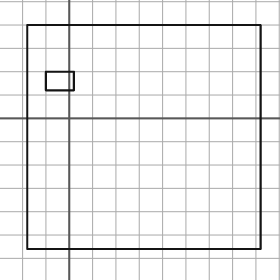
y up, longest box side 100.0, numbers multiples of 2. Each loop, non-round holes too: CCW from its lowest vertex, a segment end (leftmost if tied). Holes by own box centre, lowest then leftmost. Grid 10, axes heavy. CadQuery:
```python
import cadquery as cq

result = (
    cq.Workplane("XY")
    .moveTo(-18.0, -56.0)
    .lineTo(82.0, -56.0)
    .lineTo(82.0, 40.0)
    .lineTo(-18.0, 40.0)
    .close()
    .moveTo(-10.0, 12.0)
    .lineTo(2.0, 12.0)
    .lineTo(2.0, 20.0)
    .lineTo(-10.0, 20.0)
    .close()
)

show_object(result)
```